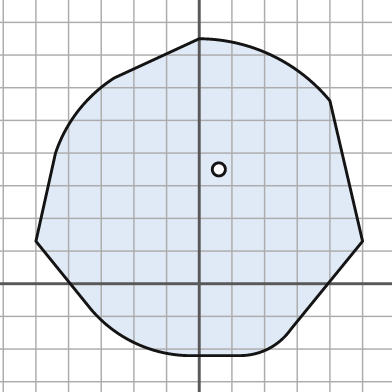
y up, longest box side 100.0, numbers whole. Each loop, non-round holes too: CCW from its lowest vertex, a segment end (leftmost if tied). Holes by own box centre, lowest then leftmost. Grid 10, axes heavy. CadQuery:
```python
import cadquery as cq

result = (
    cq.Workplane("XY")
    .moveTo(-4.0, -22.0)
    .lineTo(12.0, -22.0)
    .threePointArc((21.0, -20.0), (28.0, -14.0))
    .lineTo(50.0, 13.0)
    .lineTo(40.0, 56.0)
    .threePointArc((22.0, 70.0), (0.0, 75.0))
    .lineTo(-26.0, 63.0)
    .threePointArc((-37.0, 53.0), (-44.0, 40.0))
    .lineTo(-50.0, 13.0)
    .lineTo(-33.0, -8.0)
    .threePointArc((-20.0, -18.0), (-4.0, -22.0))
    .close()
    .moveTo(6.0, 35.0)
    .circle(2.0)
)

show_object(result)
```